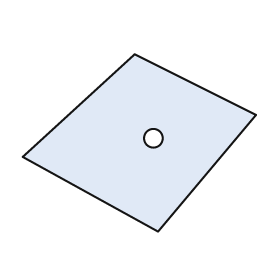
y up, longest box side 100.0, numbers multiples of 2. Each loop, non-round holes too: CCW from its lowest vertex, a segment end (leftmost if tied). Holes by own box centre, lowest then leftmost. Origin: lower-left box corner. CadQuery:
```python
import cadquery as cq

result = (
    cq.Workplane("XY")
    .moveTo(58.0, 0.0)
    .lineTo(100.0, 50.0)
    .lineTo(48.0, 76.0)
    .lineTo(0.0, 32.0)
    .close()
    .moveTo(56.0, 40.0)
    .circle(4.0)
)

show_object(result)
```